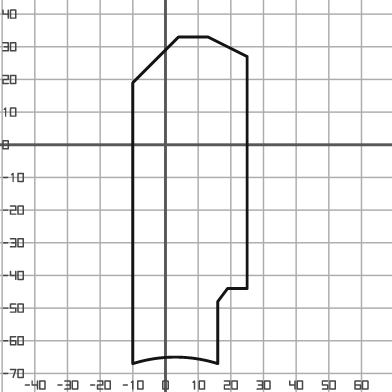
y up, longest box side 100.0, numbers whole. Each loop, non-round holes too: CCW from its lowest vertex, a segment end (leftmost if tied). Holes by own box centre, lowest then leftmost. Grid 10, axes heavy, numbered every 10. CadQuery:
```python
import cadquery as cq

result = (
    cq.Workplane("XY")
    .moveTo(-10.0, -67.0)
    .threePointArc((3.0, -65.0), (16.0, -67.0))
    .lineTo(16.0, -48.0)
    .lineTo(19.0, -44.0)
    .lineTo(25.0, -44.0)
    .lineTo(25.0, 27.0)
    .lineTo(13.0, 33.0)
    .lineTo(4.0, 33.0)
    .lineTo(-10.0, 19.0)
    .close()
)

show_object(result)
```